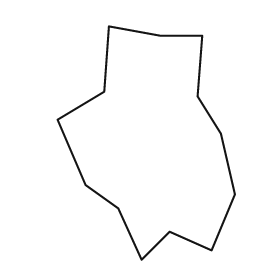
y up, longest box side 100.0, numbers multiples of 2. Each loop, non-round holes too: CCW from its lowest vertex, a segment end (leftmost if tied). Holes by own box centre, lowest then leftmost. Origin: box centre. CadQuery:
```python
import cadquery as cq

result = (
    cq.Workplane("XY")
    .moveTo(-2.0, -50.0)
    .lineTo(10.0, -38.0)
    .lineTo(28.0, -46.0)
    .lineTo(38.0, -22.0)
    .lineTo(32.0, 4.0)
    .lineTo(22.0, 20.0)
    .lineTo(24.0, 46.0)
    .lineTo(6.0, 46.0)
    .lineTo(-16.0, 50.0)
    .lineTo(-18.0, 22.0)
    .lineTo(-38.0, 10.0)
    .lineTo(-26.0, -18.0)
    .lineTo(-12.0, -28.0)
    .close()
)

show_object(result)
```